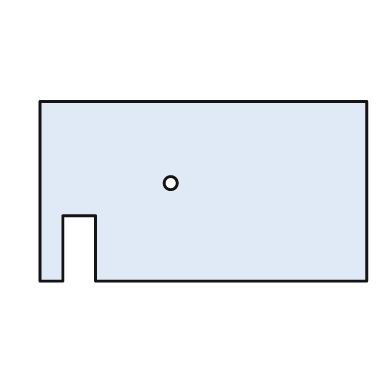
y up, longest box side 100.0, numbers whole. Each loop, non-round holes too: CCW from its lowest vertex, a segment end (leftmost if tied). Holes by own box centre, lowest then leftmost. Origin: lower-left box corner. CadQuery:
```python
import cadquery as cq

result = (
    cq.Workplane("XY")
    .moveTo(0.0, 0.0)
    .lineTo(7.0, 0.0)
    .lineTo(7.0, 20.0)
    .lineTo(17.0, 20.0)
    .lineTo(17.0, 0.0)
    .lineTo(100.0, 0.0)
    .lineTo(100.0, 55.0)
    .lineTo(0.0, 55.0)
    .close()
    .moveTo(40.0, 30.0)
    .circle(2.0)
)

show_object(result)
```